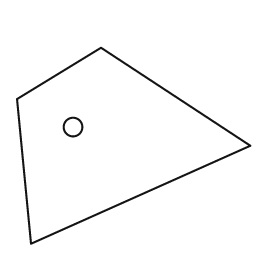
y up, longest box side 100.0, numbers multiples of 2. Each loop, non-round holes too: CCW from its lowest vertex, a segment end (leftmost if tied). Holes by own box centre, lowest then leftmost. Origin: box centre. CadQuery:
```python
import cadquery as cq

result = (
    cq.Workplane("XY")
    .moveTo(-44.0, -42.0)
    .lineTo(50.0, 0.0)
    .lineTo(-14.0, 42.0)
    .lineTo(-50.0, 20.0)
    .close()
    .moveTo(-26.0, 8.0)
    .circle(4.0)
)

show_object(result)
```